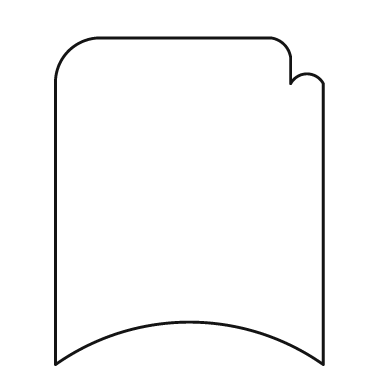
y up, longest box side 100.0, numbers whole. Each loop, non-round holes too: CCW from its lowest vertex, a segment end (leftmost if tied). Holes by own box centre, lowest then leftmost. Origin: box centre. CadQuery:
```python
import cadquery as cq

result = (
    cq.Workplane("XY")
    .moveTo(-41.0, -50.0)
    .threePointArc((0.0, -37.0), (41.0, -50.0))
    .lineTo(41.0, 36.0)
    .threePointArc((36.0, 39.0), (31.0, 36.0))
    .lineTo(31.0, 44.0)
    .threePointArc((29.0, 48.0), (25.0, 50.0))
    .lineTo(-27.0, 50.0)
    .threePointArc((-37.0, 46.0), (-41.0, 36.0))
    .close()
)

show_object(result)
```